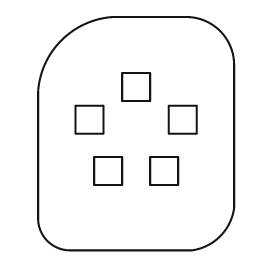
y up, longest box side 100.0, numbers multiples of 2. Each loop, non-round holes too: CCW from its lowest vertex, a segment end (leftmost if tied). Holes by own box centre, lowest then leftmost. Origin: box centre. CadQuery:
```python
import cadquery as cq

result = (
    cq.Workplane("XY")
    .moveTo(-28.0, -50.0)
    .lineTo(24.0, -50.0)
    .threePointArc((36.0, -44.0), (42.0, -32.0))
    .lineTo(42.0, 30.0)
    .threePointArc((36.0, 44.0), (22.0, 50.0))
    .lineTo(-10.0, 50.0)
    .threePointArc((-32.0, 40.0), (-42.0, 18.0))
    .lineTo(-42.0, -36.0)
    .threePointArc((-38.0, -46.0), (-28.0, -50.0))
    .close()
    .moveTo(-18.0, -22.0)
    .lineTo(-6.0, -22.0)
    .lineTo(-6.0, -10.0)
    .lineTo(-18.0, -10.0)
    .close()
    .moveTo(6.0, -22.0)
    .lineTo(18.0, -22.0)
    .lineTo(18.0, -10.0)
    .lineTo(6.0, -10.0)
    .close()
    .moveTo(-26.0, 0.0)
    .lineTo(-14.0, 0.0)
    .lineTo(-14.0, 12.0)
    .lineTo(-26.0, 12.0)
    .close()
    .moveTo(14.0, 0.0)
    .lineTo(26.0, 0.0)
    .lineTo(26.0, 12.0)
    .lineTo(14.0, 12.0)
    .close()
    .moveTo(-6.0, 14.0)
    .lineTo(6.0, 14.0)
    .lineTo(6.0, 26.0)
    .lineTo(-6.0, 26.0)
    .close()
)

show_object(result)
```